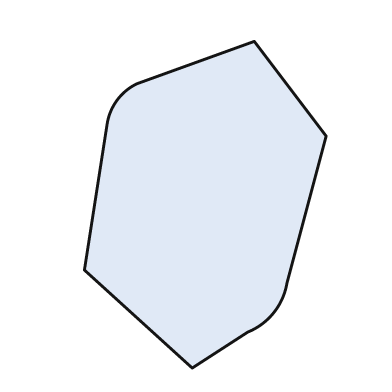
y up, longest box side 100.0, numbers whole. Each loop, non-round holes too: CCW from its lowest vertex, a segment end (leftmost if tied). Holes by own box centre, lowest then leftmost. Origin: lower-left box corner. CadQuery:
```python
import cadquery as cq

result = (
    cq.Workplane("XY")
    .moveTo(33.0, 0.0)
    .lineTo(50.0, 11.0)
    .threePointArc((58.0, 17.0), (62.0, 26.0))
    .lineTo(74.0, 71.0)
    .lineTo(52.0, 100.0)
    .lineTo(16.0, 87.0)
    .threePointArc((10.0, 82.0), (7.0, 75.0))
    .lineTo(0.0, 30.0)
    .close()
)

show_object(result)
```